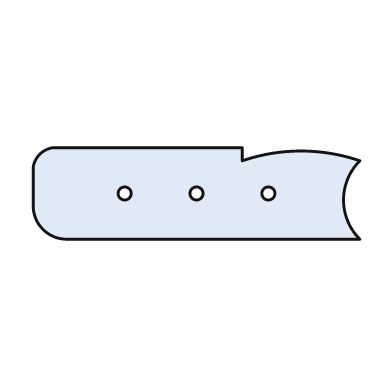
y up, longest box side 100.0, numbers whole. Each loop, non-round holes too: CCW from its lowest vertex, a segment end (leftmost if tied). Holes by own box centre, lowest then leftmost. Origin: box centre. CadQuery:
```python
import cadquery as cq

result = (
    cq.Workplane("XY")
    .moveTo(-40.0, -14.0)
    .lineTo(50.0, -14.0)
    .threePointArc((45.0, -2.0), (50.0, 10.0))
    .threePointArc((32.0, 13.0), (14.0, 10.0))
    .lineTo(14.0, 14.0)
    .lineTo(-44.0, 14.0)
    .threePointArc((-48.0, 12.0), (-50.0, 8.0))
    .lineTo(-50.0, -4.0)
    .threePointArc((-47.0, -11.0), (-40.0, -14.0))
    .close()
    .moveTo(-22.0, 0.0)
    .circle(2.0)
    .moveTo(0.0, 0.0)
    .circle(2.0)
    .moveTo(22.0, 0.0)
    .circle(2.0)
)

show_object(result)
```